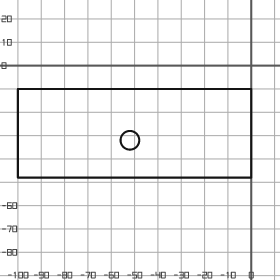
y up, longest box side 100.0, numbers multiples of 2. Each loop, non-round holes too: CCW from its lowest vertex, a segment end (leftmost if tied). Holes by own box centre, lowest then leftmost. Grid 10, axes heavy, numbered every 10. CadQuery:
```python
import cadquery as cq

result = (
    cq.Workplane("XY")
    .moveTo(-100.0, -48.0)
    .lineTo(0.0, -48.0)
    .lineTo(0.0, -10.0)
    .lineTo(-100.0, -10.0)
    .close()
    .moveTo(-52.0, -32.0)
    .circle(4.0)
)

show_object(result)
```